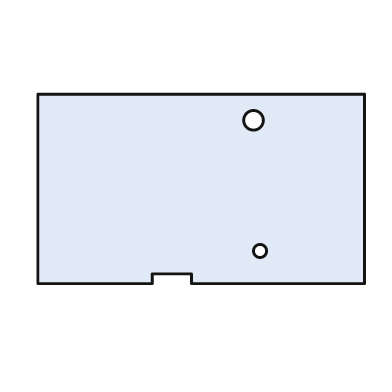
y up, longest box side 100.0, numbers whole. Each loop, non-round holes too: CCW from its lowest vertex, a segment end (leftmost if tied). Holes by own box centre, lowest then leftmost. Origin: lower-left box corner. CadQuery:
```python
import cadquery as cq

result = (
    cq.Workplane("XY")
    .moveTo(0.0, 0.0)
    .lineTo(35.0, 0.0)
    .lineTo(35.0, 3.0)
    .lineTo(47.0, 3.0)
    .lineTo(47.0, 0.0)
    .lineTo(100.0, 0.0)
    .lineTo(100.0, 58.0)
    .lineTo(0.0, 58.0)
    .close()
    .moveTo(68.0, 10.0)
    .circle(2.0)
    .moveTo(66.0, 50.0)
    .circle(3.0)
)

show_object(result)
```